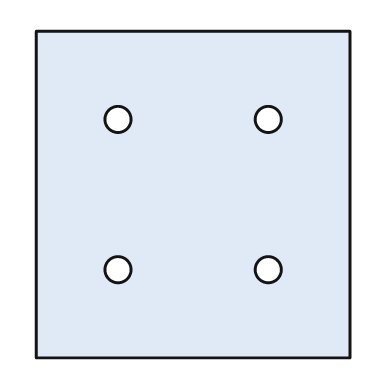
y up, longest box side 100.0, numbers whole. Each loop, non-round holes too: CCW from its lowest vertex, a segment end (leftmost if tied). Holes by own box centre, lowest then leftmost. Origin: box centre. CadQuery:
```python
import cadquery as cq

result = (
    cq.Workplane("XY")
    .moveTo(-48.0, -50.0)
    .lineTo(48.0, -50.0)
    .lineTo(48.0, 50.0)
    .lineTo(-48.0, 50.0)
    .close()
    .moveTo(-23.0, -23.0)
    .circle(4.0)
    .moveTo(23.0, -23.0)
    .circle(4.0)
    .moveTo(-23.0, 23.0)
    .circle(4.0)
    .moveTo(23.0, 23.0)
    .circle(4.0)
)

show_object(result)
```